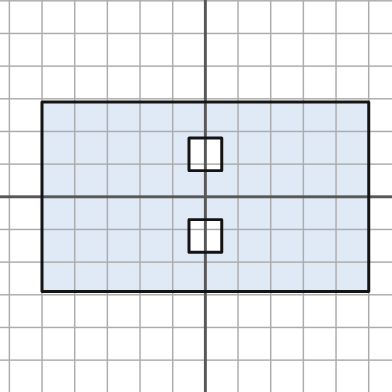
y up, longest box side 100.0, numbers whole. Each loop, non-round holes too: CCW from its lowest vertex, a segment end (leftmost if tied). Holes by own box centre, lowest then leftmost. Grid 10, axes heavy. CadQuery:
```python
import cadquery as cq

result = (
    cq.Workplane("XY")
    .moveTo(-50.0, -29.0)
    .lineTo(50.0, -29.0)
    .lineTo(50.0, 29.0)
    .lineTo(-50.0, 29.0)
    .close()
    .moveTo(-5.0, -17.0)
    .lineTo(5.0, -17.0)
    .lineTo(5.0, -7.0)
    .lineTo(-5.0, -7.0)
    .close()
    .moveTo(-5.0, 8.0)
    .lineTo(5.0, 8.0)
    .lineTo(5.0, 18.0)
    .lineTo(-5.0, 18.0)
    .close()
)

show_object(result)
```